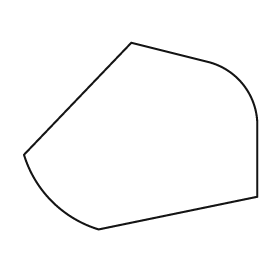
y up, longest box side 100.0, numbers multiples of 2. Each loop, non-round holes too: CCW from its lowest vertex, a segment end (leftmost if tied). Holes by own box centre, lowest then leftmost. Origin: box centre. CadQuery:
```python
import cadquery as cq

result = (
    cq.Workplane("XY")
    .moveTo(-18.0, -40.0)
    .lineTo(50.0, -26.0)
    .lineTo(50.0, 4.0)
    .threePointArc((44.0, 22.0), (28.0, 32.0))
    .lineTo(-4.0, 40.0)
    .lineTo(-50.0, -8.0)
    .threePointArc((-38.0, -28.0), (-18.0, -40.0))
    .close()
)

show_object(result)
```